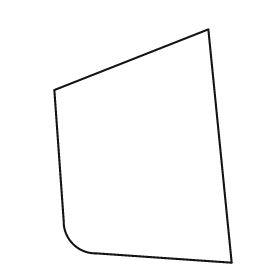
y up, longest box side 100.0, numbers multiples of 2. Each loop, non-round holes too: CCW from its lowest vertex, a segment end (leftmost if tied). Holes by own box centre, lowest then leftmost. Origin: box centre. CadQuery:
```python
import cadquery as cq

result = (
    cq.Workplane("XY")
    .moveTo(38.0, -50.0)
    .lineTo(28.0, 50.0)
    .lineTo(-38.0, 24.0)
    .lineTo(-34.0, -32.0)
    .threePointArc((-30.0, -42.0), (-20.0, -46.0))
    .close()
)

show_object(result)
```